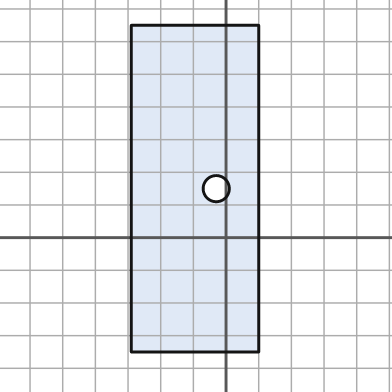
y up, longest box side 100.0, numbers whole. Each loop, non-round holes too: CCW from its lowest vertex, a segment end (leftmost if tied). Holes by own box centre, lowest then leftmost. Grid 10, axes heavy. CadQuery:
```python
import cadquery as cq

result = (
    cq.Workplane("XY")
    .moveTo(-29.0, -35.0)
    .lineTo(10.0, -35.0)
    .lineTo(10.0, 65.0)
    .lineTo(-29.0, 65.0)
    .close()
    .moveTo(-3.0, 15.0)
    .circle(4.0)
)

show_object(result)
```